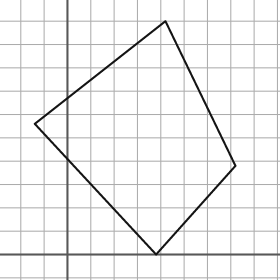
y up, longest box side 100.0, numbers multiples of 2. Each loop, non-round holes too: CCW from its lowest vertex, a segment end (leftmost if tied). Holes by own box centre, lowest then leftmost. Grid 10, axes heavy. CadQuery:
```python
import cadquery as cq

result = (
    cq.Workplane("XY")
    .moveTo(38.0, 0.0)
    .lineTo(72.0, 38.0)
    .lineTo(42.0, 100.0)
    .lineTo(-14.0, 56.0)
    .close()
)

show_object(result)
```